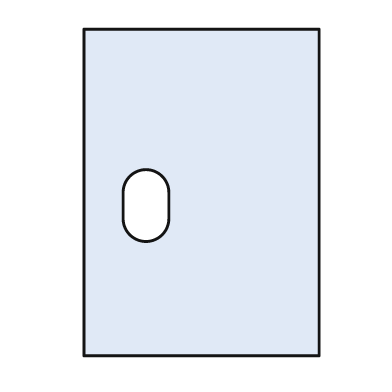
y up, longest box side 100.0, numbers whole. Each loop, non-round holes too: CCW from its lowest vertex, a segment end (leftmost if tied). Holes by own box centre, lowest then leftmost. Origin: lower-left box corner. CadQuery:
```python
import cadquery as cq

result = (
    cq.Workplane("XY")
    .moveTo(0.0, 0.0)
    .lineTo(72.0, 0.0)
    .lineTo(72.0, 100.0)
    .lineTo(0.0, 100.0)
    .close()
    .moveTo(12.0, 42.0)
    .threePointArc((19.0, 35.0), (26.0, 42.0))
    .lineTo(26.0, 50.0)
    .threePointArc((19.0, 57.0), (12.0, 50.0))
    .close()
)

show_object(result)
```